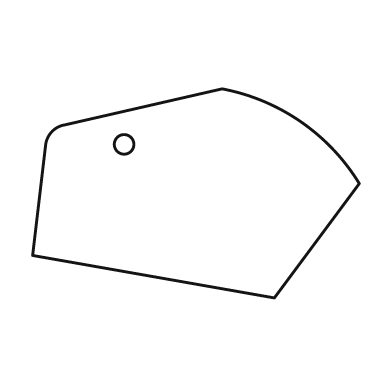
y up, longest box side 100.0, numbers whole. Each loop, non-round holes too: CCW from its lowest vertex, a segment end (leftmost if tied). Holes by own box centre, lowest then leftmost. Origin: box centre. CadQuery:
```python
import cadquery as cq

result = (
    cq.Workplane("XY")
    .moveTo(24.0, -32.0)
    .lineTo(50.0, 3.0)
    .threePointArc((32.0, 22.0), (8.0, 32.0))
    .lineTo(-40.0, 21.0)
    .threePointArc((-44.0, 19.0), (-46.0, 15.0))
    .lineTo(-50.0, -19.0)
    .close()
    .moveTo(-22.0, 15.0)
    .circle(3.0)
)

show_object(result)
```